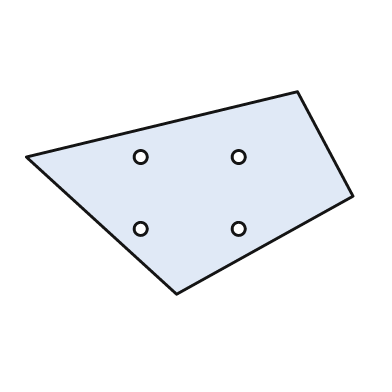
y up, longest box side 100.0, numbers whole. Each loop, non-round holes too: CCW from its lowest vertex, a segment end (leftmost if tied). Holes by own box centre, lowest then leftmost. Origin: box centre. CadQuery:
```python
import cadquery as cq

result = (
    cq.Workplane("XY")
    .moveTo(-4.0, -31.0)
    .lineTo(50.0, -1.0)
    .lineTo(33.0, 31.0)
    .lineTo(-50.0, 11.0)
    .close()
    .moveTo(-15.0, -11.0)
    .circle(2.0)
    .moveTo(15.0, -11.0)
    .circle(2.0)
    .moveTo(-15.0, 11.0)
    .circle(2.0)
    .moveTo(15.0, 11.0)
    .circle(2.0)
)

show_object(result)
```